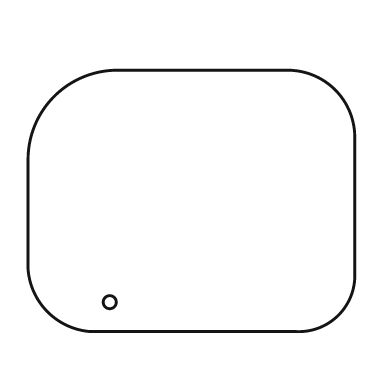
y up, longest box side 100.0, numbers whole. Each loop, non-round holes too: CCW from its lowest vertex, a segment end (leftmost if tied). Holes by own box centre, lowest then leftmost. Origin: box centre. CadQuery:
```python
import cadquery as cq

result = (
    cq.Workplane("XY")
    .moveTo(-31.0, -40.0)
    .lineTo(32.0, -40.0)
    .threePointArc((45.0, -35.0), (50.0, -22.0))
    .lineTo(50.0, 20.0)
    .threePointArc((44.0, 34.0), (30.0, 40.0))
    .lineTo(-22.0, 40.0)
    .threePointArc((-42.0, 32.0), (-50.0, 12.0))
    .lineTo(-50.0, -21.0)
    .threePointArc((-44.0, -34.0), (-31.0, -40.0))
    .close()
    .moveTo(-25.0, -31.0)
    .circle(2.0)
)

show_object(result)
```